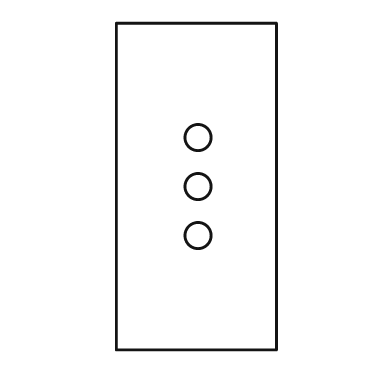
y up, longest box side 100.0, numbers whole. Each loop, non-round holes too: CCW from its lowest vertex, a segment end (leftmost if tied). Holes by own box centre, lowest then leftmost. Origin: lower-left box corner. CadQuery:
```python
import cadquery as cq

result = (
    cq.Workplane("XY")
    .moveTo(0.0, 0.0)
    .lineTo(49.0, 0.0)
    .lineTo(49.0, 100.0)
    .lineTo(0.0, 100.0)
    .close()
    .moveTo(25.0, 35.0)
    .circle(4.0)
    .moveTo(25.0, 50.0)
    .circle(4.0)
    .moveTo(25.0, 65.0)
    .circle(4.0)
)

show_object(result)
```